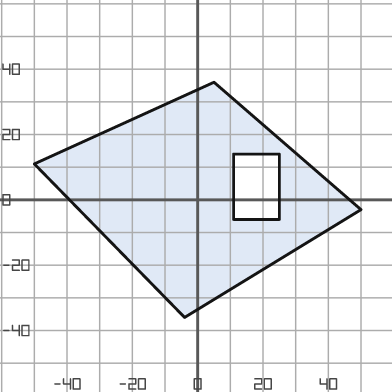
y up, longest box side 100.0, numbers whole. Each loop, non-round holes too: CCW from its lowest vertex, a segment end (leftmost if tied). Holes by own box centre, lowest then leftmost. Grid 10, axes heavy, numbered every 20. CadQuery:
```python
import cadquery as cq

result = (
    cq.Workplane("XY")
    .moveTo(-4.0, -36.0)
    .lineTo(50.0, -3.0)
    .lineTo(5.0, 36.0)
    .lineTo(-50.0, 11.0)
    .close()
    .moveTo(11.0, -6.0)
    .lineTo(25.0, -6.0)
    .lineTo(25.0, 14.0)
    .lineTo(11.0, 14.0)
    .close()
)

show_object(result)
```